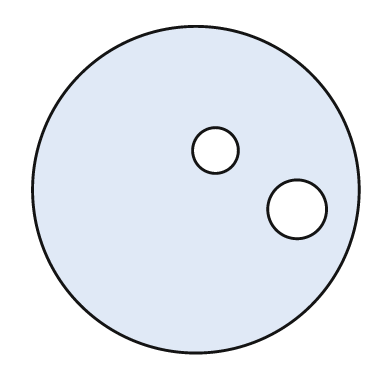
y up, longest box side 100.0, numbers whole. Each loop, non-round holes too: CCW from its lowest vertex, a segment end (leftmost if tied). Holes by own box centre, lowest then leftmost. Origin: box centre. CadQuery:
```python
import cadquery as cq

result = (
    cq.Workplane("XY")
    .moveTo(0.0, 0.0)
    .circle(50.0)
    .moveTo(31.0, -6.0)
    .circle(9.0)
    .moveTo(6.0, 12.0)
    .circle(7.0)
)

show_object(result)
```